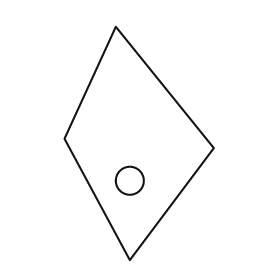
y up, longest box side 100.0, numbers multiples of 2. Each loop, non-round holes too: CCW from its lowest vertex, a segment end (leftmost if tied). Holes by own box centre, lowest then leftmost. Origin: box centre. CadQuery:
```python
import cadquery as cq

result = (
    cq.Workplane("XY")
    .moveTo(-4.0, -50.0)
    .lineTo(32.0, -2.0)
    .lineTo(-10.0, 50.0)
    .lineTo(-32.0, 2.0)
    .close()
    .moveTo(-4.0, -16.0)
    .circle(6.0)
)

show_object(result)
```